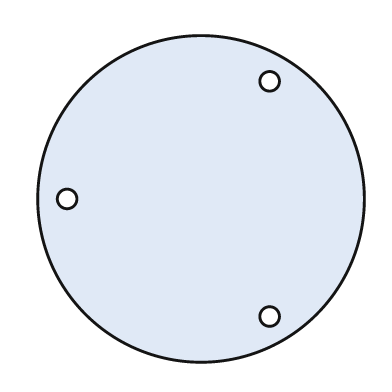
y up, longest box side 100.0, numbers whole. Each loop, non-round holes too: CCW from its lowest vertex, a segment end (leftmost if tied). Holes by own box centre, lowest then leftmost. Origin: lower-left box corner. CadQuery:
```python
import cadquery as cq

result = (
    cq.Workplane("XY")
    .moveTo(50.0, 50.0)
    .circle(50.0)
    .moveTo(71.0, 14.0)
    .circle(3.0)
    .moveTo(9.0, 50.0)
    .circle(3.0)
    .moveTo(71.0, 86.0)
    .circle(3.0)
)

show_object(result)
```